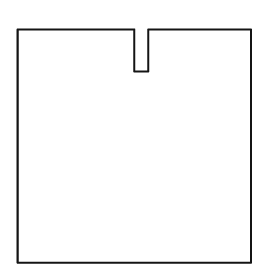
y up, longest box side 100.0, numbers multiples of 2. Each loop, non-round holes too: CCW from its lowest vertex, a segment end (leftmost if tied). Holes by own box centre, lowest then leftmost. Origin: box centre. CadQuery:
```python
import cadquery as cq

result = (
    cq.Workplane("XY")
    .moveTo(-50.0, -50.0)
    .lineTo(50.0, -50.0)
    .lineTo(50.0, 50.0)
    .lineTo(6.0, 50.0)
    .lineTo(6.0, 32.0)
    .lineTo(0.0, 32.0)
    .lineTo(0.0, 50.0)
    .lineTo(-50.0, 50.0)
    .close()
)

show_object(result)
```